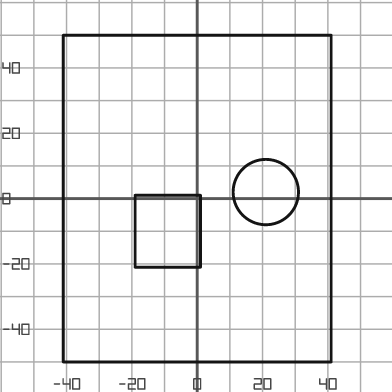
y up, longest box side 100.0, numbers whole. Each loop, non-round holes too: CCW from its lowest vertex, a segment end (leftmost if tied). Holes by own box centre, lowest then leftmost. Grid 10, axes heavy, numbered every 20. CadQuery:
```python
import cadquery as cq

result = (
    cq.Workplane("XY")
    .moveTo(-41.0, -50.0)
    .lineTo(41.0, -50.0)
    .lineTo(41.0, 50.0)
    .lineTo(-41.0, 50.0)
    .close()
    .moveTo(-19.0, -21.0)
    .lineTo(1.0, -21.0)
    .lineTo(1.0, 1.0)
    .lineTo(-19.0, 1.0)
    .close()
    .moveTo(21.0, 2.0)
    .circle(10.0)
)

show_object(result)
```